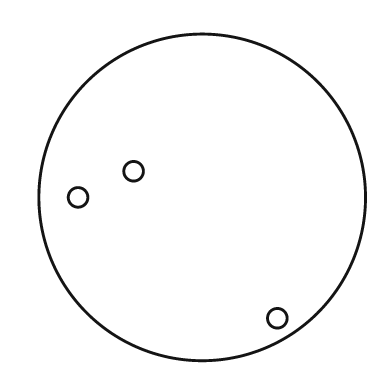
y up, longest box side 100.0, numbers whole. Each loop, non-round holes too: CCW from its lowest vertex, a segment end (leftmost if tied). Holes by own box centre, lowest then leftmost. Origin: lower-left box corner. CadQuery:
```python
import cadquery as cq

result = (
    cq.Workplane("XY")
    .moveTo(50.0, 50.0)
    .circle(50.0)
    .moveTo(73.0, 13.0)
    .circle(3.0)
    .moveTo(12.0, 50.0)
    .circle(3.0)
    .moveTo(29.0, 58.0)
    .circle(3.0)
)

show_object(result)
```